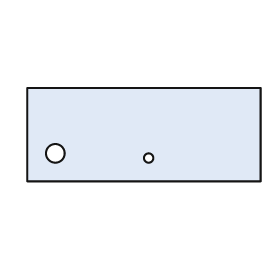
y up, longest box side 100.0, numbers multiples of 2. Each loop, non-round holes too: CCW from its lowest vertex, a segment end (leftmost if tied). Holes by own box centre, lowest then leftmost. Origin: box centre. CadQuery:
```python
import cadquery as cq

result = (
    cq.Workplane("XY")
    .moveTo(-50.0, -20.0)
    .lineTo(50.0, -20.0)
    .lineTo(50.0, 20.0)
    .lineTo(-50.0, 20.0)
    .close()
    .moveTo(2.0, -10.0)
    .circle(2.0)
    .moveTo(-38.0, -8.0)
    .circle(4.0)
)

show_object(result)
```